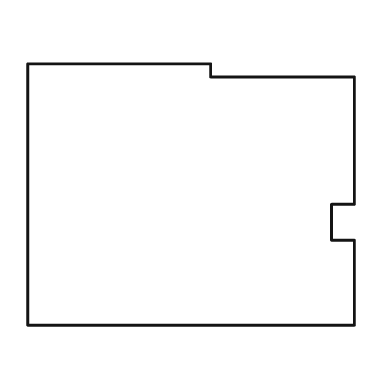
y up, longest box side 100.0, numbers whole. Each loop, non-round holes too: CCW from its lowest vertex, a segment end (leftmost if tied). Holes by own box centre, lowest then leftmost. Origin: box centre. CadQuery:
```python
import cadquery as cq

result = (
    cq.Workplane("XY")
    .moveTo(-50.0, -40.0)
    .lineTo(50.0, -40.0)
    .lineTo(50.0, -14.0)
    .lineTo(43.0, -14.0)
    .lineTo(43.0, -3.0)
    .lineTo(50.0, -3.0)
    .lineTo(50.0, 36.0)
    .lineTo(6.0, 36.0)
    .lineTo(6.0, 40.0)
    .lineTo(-50.0, 40.0)
    .close()
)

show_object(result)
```